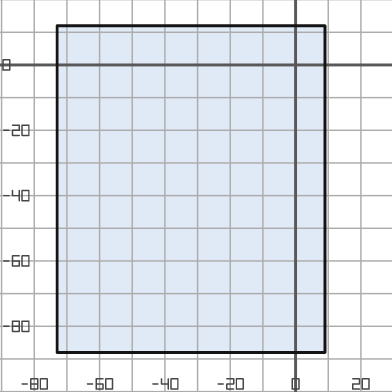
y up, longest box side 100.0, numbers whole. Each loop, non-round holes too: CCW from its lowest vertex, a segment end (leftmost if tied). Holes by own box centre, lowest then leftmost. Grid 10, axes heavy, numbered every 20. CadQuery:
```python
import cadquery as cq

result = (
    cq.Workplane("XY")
    .moveTo(-73.0, -88.0)
    .lineTo(9.0, -88.0)
    .lineTo(9.0, 12.0)
    .lineTo(-73.0, 12.0)
    .close()
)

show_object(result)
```